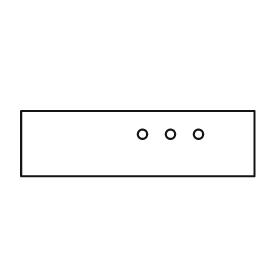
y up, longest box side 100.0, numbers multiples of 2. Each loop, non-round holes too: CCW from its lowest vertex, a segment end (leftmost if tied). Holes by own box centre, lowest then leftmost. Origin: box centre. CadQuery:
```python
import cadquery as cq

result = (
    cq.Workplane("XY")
    .moveTo(-50.0, -14.0)
    .lineTo(50.0, -14.0)
    .lineTo(50.0, 14.0)
    .lineTo(-50.0, 14.0)
    .close()
    .moveTo(2.0, 4.0)
    .circle(2.0)
    .moveTo(14.0, 4.0)
    .circle(2.0)
    .moveTo(26.0, 4.0)
    .circle(2.0)
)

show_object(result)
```